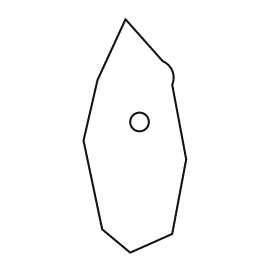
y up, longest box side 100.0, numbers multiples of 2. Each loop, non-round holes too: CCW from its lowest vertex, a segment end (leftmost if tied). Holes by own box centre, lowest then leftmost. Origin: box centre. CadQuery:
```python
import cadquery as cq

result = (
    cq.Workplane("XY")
    .moveTo(-2.0, -50.0)
    .lineTo(16.0, -42.0)
    .lineTo(22.0, -10.0)
    .lineTo(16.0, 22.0)
    .threePointArc((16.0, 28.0), (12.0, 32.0))
    .lineTo(-4.0, 50.0)
    .lineTo(-16.0, 24.0)
    .lineTo(-22.0, -2.0)
    .lineTo(-14.0, -40.0)
    .close()
    .moveTo(2.0, 6.0)
    .circle(4.0)
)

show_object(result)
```